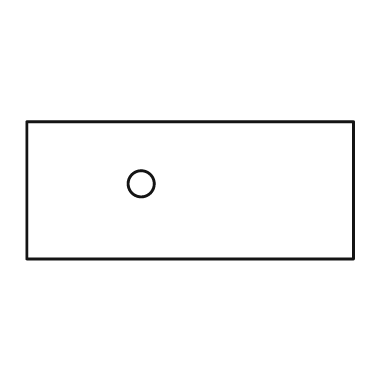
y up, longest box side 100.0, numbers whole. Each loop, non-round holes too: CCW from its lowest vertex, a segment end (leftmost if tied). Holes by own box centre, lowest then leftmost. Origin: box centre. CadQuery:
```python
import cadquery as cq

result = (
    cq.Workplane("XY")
    .moveTo(-50.0, -21.0)
    .lineTo(50.0, -21.0)
    .lineTo(50.0, 21.0)
    .lineTo(-50.0, 21.0)
    .close()
    .moveTo(-15.0, 2.0)
    .circle(4.0)
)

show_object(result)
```